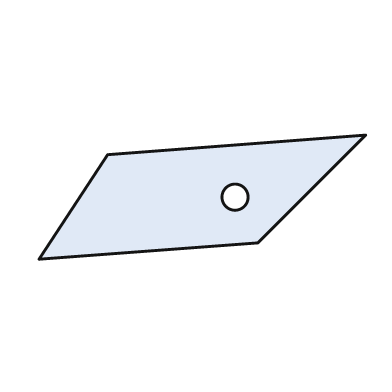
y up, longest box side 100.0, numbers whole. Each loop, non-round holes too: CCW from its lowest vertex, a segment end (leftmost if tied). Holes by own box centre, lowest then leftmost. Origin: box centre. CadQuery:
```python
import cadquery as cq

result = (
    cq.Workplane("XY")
    .moveTo(-50.0, -19.0)
    .lineTo(17.0, -14.0)
    .lineTo(50.0, 19.0)
    .lineTo(-29.0, 13.0)
    .close()
    .moveTo(10.0, 0.0)
    .circle(4.0)
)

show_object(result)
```